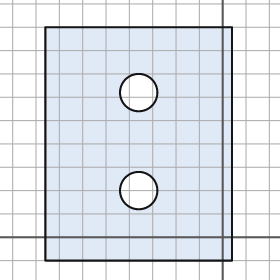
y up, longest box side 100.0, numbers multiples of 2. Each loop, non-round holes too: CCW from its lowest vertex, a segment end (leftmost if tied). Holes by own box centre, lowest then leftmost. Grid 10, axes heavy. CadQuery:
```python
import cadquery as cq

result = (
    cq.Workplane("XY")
    .moveTo(-76.0, -10.0)
    .lineTo(4.0, -10.0)
    .lineTo(4.0, 90.0)
    .lineTo(-76.0, 90.0)
    .close()
    .moveTo(-36.0, 20.0)
    .circle(8.0)
    .moveTo(-36.0, 62.0)
    .circle(8.0)
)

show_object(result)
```